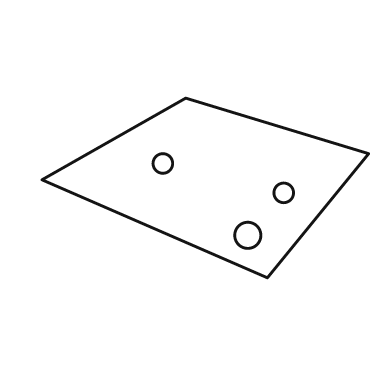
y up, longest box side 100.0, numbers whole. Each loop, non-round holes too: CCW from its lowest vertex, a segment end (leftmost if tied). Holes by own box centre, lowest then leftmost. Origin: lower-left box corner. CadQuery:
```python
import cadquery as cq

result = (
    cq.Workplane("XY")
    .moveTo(69.0, 0.0)
    .lineTo(100.0, 38.0)
    .lineTo(44.0, 55.0)
    .lineTo(0.0, 30.0)
    .close()
    .moveTo(63.0, 13.0)
    .circle(4.0)
    .moveTo(74.0, 26.0)
    .circle(3.0)
    .moveTo(37.0, 35.0)
    .circle(3.0)
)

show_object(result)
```